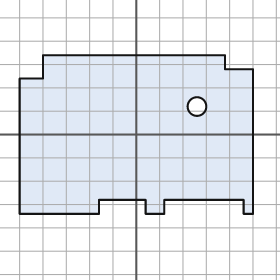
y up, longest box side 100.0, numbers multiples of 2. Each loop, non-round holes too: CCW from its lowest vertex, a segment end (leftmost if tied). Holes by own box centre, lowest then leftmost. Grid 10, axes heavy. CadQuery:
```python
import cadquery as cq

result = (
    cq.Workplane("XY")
    .moveTo(-50.0, -34.0)
    .lineTo(-16.0, -34.0)
    .lineTo(-16.0, -28.0)
    .lineTo(4.0, -28.0)
    .lineTo(4.0, -34.0)
    .lineTo(12.0, -34.0)
    .lineTo(12.0, -28.0)
    .lineTo(46.0, -28.0)
    .lineTo(46.0, -34.0)
    .lineTo(50.0, -34.0)
    .lineTo(50.0, 28.0)
    .lineTo(38.0, 28.0)
    .lineTo(38.0, 34.0)
    .lineTo(-40.0, 34.0)
    .lineTo(-40.0, 24.0)
    .lineTo(-50.0, 24.0)
    .close()
    .moveTo(26.0, 12.0)
    .circle(4.0)
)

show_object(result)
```